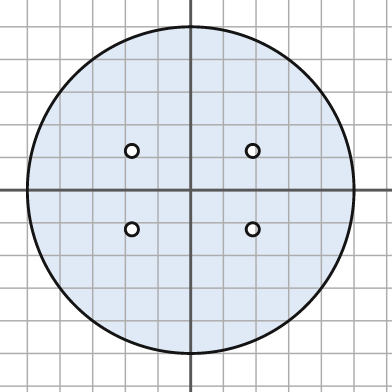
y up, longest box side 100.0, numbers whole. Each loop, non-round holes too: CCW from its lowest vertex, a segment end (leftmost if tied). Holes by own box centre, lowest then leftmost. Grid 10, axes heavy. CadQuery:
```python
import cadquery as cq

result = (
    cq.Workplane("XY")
    .moveTo(0.0, 0.0)
    .circle(50.0)
    .moveTo(-18.0, -12.0)
    .circle(2.0)
    .moveTo(19.0, -12.0)
    .circle(2.0)
    .moveTo(-18.0, 12.0)
    .circle(2.0)
    .moveTo(19.0, 12.0)
    .circle(2.0)
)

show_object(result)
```